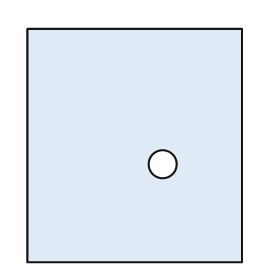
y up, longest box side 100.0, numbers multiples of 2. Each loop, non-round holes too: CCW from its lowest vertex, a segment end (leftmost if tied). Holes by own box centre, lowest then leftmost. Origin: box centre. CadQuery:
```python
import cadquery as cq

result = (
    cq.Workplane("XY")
    .moveTo(-46.0, -50.0)
    .lineTo(46.0, -50.0)
    .lineTo(46.0, 50.0)
    .lineTo(-46.0, 50.0)
    .close()
    .moveTo(12.0, -8.0)
    .circle(6.0)
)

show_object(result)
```